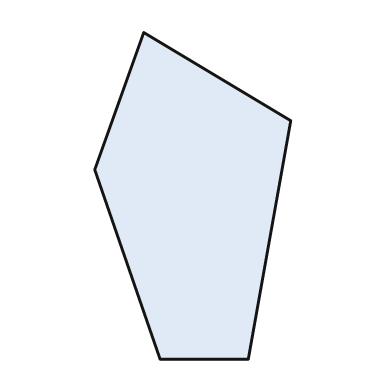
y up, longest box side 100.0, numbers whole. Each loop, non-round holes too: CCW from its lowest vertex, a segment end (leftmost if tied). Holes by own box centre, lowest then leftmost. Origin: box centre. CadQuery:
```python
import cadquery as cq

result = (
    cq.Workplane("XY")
    .moveTo(-10.0, -50.0)
    .lineTo(17.0, -50.0)
    .lineTo(30.0, 23.0)
    .lineTo(-15.0, 50.0)
    .lineTo(-30.0, 8.0)
    .close()
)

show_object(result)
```